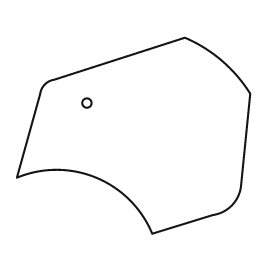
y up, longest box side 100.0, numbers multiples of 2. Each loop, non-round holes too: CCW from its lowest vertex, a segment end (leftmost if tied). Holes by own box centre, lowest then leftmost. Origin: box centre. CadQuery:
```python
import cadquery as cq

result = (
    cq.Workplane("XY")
    .moveTo(8.0, -42.0)
    .lineTo(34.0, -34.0)
    .threePointArc((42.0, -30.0), (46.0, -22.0))
    .lineTo(50.0, 18.0)
    .threePointArc((38.0, 32.0), (22.0, 42.0))
    .lineTo(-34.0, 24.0)
    .threePointArc((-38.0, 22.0), (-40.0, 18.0))
    .lineTo(-50.0, -18.0)
    .threePointArc((-16.0, -18.0), (8.0, -42.0))
    .close()
    .moveTo(-20.0, 14.0)
    .circle(2.0)
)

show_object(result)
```